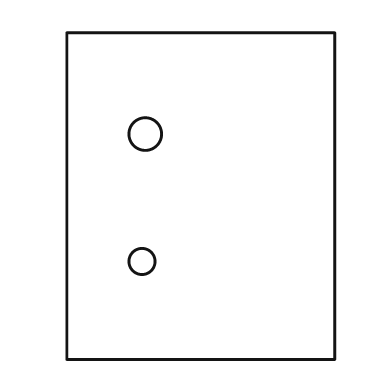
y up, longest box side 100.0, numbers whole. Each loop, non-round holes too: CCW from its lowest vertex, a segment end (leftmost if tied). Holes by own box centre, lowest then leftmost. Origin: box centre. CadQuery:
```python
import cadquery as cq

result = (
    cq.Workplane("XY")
    .moveTo(-41.0, -50.0)
    .lineTo(41.0, -50.0)
    .lineTo(41.0, 50.0)
    .lineTo(-41.0, 50.0)
    .close()
    .moveTo(-18.0, -20.0)
    .circle(4.0)
    .moveTo(-17.0, 19.0)
    .circle(5.0)
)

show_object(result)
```